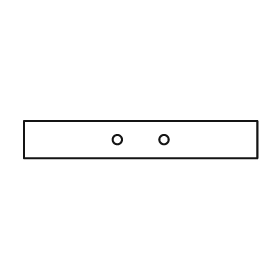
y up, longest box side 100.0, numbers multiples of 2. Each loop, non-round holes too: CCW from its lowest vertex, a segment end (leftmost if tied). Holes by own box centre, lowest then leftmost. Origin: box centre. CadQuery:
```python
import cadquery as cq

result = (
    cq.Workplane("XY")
    .moveTo(-50.0, -8.0)
    .lineTo(50.0, -8.0)
    .lineTo(50.0, 8.0)
    .lineTo(-50.0, 8.0)
    .close()
    .moveTo(-10.0, 0.0)
    .circle(2.0)
    .moveTo(10.0, 0.0)
    .circle(2.0)
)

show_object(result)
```